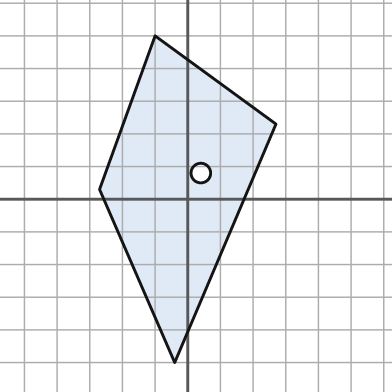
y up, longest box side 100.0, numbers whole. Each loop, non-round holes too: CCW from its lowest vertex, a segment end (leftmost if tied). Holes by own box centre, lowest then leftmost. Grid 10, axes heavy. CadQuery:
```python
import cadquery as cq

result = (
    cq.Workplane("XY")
    .moveTo(-4.0, -50.0)
    .lineTo(27.0, 23.0)
    .lineTo(-10.0, 50.0)
    .lineTo(-27.0, 3.0)
    .close()
    .moveTo(4.0, 8.0)
    .circle(3.0)
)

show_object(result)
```